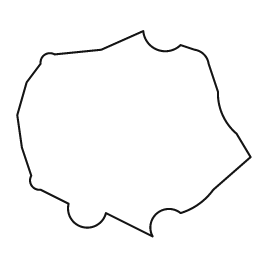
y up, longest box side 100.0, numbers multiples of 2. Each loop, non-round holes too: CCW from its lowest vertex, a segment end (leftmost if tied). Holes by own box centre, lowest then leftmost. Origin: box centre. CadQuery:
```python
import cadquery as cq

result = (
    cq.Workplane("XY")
    .moveTo(8.0, -44.0)
    .threePointArc((10.0, -34.0), (20.0, -34.0))
    .threePointArc((28.0, -30.0), (34.0, -24.0))
    .lineTo(50.0, -10.0)
    .lineTo(44.0, 0.0)
    .threePointArc((38.0, 8.0), (36.0, 18.0))
    .lineTo(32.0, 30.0)
    .threePointArc((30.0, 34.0), (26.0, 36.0))
    .lineTo(20.0, 38.0)
    .threePointArc((10.0, 36.0), (4.0, 44.0))
    .lineTo(-14.0, 36.0)
    .lineTo(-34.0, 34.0)
    .threePointArc((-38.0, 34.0), (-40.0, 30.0))
    .lineTo(-46.0, 22.0)
    .lineTo(-50.0, 8.0)
    .lineTo(-48.0, -6.0)
    .lineTo(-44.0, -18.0)
    .threePointArc((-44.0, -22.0), (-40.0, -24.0))
    .lineTo(-28.0, -30.0)
    .threePointArc((-22.0, -40.0), (-12.0, -34.0))
    .close()
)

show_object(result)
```